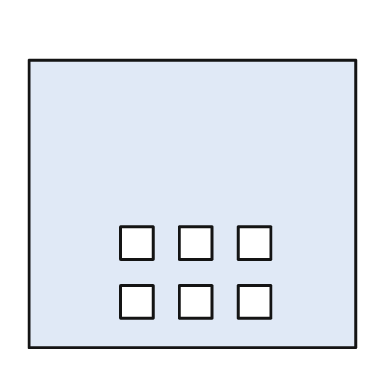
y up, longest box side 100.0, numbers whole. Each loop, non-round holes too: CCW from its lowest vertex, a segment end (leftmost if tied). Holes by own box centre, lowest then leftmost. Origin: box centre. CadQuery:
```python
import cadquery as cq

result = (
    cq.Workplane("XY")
    .moveTo(-50.0, -44.0)
    .lineTo(50.0, -44.0)
    .lineTo(50.0, 44.0)
    .lineTo(-50.0, 44.0)
    .close()
    .moveTo(-22.0, -35.0)
    .lineTo(-12.0, -35.0)
    .lineTo(-12.0, -25.0)
    .lineTo(-22.0, -25.0)
    .close()
    .moveTo(-4.0, -35.0)
    .lineTo(6.0, -35.0)
    .lineTo(6.0, -25.0)
    .lineTo(-4.0, -25.0)
    .close()
    .moveTo(14.0, -35.0)
    .lineTo(24.0, -35.0)
    .lineTo(24.0, -25.0)
    .lineTo(14.0, -25.0)
    .close()
    .moveTo(-22.0, -17.0)
    .lineTo(-12.0, -17.0)
    .lineTo(-12.0, -7.0)
    .lineTo(-22.0, -7.0)
    .close()
    .moveTo(-4.0, -17.0)
    .lineTo(6.0, -17.0)
    .lineTo(6.0, -7.0)
    .lineTo(-4.0, -7.0)
    .close()
    .moveTo(14.0, -17.0)
    .lineTo(24.0, -17.0)
    .lineTo(24.0, -7.0)
    .lineTo(14.0, -7.0)
    .close()
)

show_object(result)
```